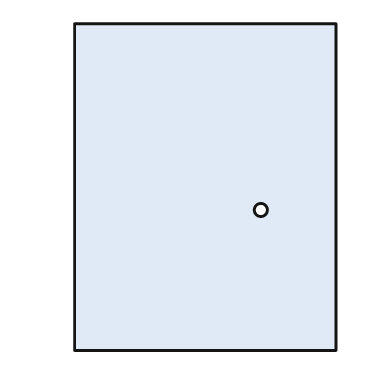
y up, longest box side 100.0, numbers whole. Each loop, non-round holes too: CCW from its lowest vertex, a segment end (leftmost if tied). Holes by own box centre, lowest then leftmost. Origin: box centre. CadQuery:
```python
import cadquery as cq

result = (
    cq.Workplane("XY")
    .moveTo(-40.0, -50.0)
    .lineTo(40.0, -50.0)
    .lineTo(40.0, 50.0)
    .lineTo(-40.0, 50.0)
    .close()
    .moveTo(17.0, -7.0)
    .circle(2.0)
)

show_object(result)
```